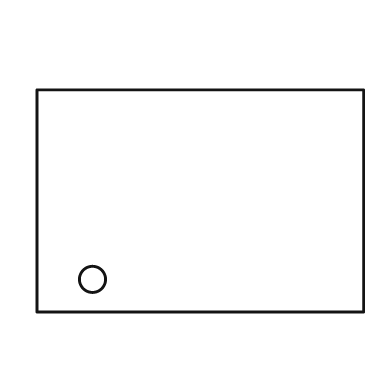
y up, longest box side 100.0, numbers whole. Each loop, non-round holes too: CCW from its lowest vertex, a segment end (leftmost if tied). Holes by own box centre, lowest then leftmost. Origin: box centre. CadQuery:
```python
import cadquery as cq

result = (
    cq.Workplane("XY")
    .moveTo(-50.0, -34.0)
    .lineTo(50.0, -34.0)
    .lineTo(50.0, 34.0)
    .lineTo(-50.0, 34.0)
    .close()
    .moveTo(-33.0, -24.0)
    .circle(4.0)
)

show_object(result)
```